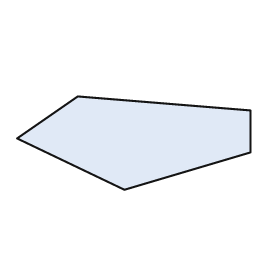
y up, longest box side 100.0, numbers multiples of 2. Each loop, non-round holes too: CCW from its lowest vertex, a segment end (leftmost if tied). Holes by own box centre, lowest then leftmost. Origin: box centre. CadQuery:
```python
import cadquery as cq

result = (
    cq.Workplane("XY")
    .moveTo(-4.0, -20.0)
    .lineTo(50.0, -4.0)
    .lineTo(50.0, 14.0)
    .lineTo(-24.0, 20.0)
    .lineTo(-50.0, 2.0)
    .close()
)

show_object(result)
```